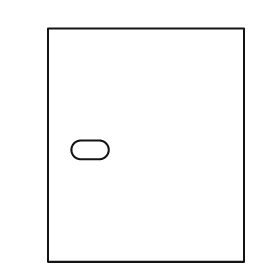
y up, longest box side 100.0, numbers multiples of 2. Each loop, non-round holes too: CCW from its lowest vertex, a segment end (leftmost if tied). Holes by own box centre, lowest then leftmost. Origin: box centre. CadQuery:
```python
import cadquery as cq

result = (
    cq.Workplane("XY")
    .moveTo(-42.0, -50.0)
    .lineTo(42.0, -50.0)
    .lineTo(42.0, 50.0)
    .lineTo(-42.0, 50.0)
    .close()
    .moveTo(-28.0, -6.0)
    .lineTo(-20.0, -6.0)
    .threePointArc((-16.0, -2.0), (-20.0, 2.0))
    .lineTo(-28.0, 2.0)
    .threePointArc((-32.0, -2.0), (-28.0, -6.0))
    .close()
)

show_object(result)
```